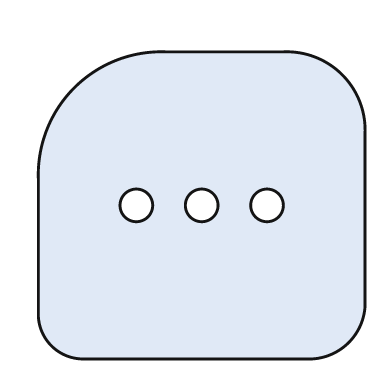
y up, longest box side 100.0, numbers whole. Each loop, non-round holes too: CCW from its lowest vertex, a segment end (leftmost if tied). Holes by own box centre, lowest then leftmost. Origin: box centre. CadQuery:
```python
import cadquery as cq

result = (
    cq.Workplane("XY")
    .moveTo(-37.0, -47.0)
    .lineTo(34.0, -47.0)
    .threePointArc((45.0, -42.0), (50.0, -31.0))
    .lineTo(50.0, 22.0)
    .threePointArc((43.0, 40.0), (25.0, 47.0))
    .lineTo(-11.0, 47.0)
    .threePointArc((-39.0, 36.0), (-50.0, 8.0))
    .lineTo(-50.0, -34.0)
    .threePointArc((-46.0, -43.0), (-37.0, -47.0))
    .close()
    .moveTo(-20.0, 0.0)
    .circle(5.0)
    .moveTo(0.0, 0.0)
    .circle(5.0)
    .moveTo(20.0, 0.0)
    .circle(5.0)
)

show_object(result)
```